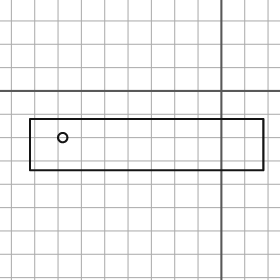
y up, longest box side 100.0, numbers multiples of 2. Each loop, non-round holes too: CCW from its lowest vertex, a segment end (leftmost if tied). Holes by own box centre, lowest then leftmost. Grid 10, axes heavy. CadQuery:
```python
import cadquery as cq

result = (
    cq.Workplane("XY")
    .moveTo(-82.0, -34.0)
    .lineTo(18.0, -34.0)
    .lineTo(18.0, -12.0)
    .lineTo(-82.0, -12.0)
    .close()
    .moveTo(-68.0, -20.0)
    .circle(2.0)
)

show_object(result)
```